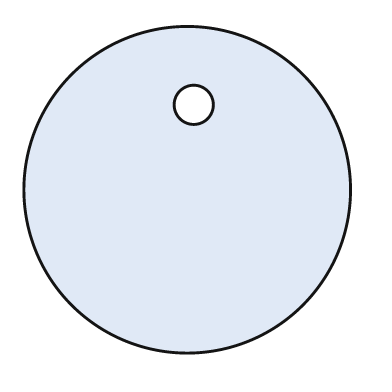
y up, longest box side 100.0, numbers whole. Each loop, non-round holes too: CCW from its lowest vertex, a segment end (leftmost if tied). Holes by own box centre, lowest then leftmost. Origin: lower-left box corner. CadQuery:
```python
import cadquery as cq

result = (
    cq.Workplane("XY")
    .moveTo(50.0, 50.0)
    .circle(50.0)
    .moveTo(52.0, 76.0)
    .circle(6.0)
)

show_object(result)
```